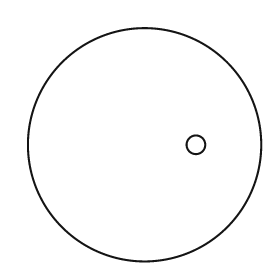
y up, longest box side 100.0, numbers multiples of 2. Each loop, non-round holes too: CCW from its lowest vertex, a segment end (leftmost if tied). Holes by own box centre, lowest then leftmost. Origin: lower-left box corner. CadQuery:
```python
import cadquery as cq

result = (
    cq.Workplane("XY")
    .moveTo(50.0, 50.0)
    .circle(50.0)
    .moveTo(72.0, 50.0)
    .circle(4.0)
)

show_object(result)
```